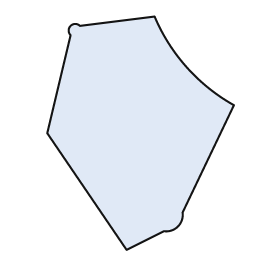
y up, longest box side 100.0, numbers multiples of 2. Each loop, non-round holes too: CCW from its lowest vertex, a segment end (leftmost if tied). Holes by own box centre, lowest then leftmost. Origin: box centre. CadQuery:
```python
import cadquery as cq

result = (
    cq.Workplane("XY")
    .moveTo(-6.0, -50.0)
    .lineTo(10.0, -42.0)
    .threePointArc((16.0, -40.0), (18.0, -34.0))
    .lineTo(40.0, 12.0)
    .threePointArc((20.0, 28.0), (6.0, 50.0))
    .lineTo(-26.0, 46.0)
    .threePointArc((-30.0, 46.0), (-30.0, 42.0))
    .lineTo(-40.0, 0.0)
    .close()
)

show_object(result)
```